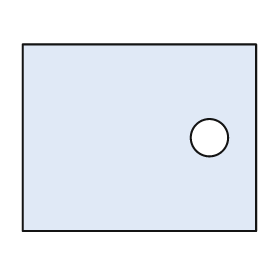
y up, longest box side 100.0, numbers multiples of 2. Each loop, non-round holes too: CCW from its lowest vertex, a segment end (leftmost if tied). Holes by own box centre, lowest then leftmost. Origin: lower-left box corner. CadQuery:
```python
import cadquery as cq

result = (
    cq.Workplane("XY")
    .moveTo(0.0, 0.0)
    .lineTo(100.0, 0.0)
    .lineTo(100.0, 80.0)
    .lineTo(0.0, 80.0)
    .close()
    .moveTo(80.0, 40.0)
    .circle(8.0)
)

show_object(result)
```